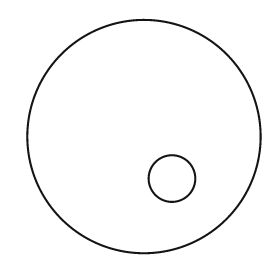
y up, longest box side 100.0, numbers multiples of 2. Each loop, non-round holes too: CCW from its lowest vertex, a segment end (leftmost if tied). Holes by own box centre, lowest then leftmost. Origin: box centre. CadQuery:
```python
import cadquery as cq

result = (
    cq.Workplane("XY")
    .moveTo(0.0, 0.0)
    .circle(50.0)
    .moveTo(12.0, -18.0)
    .circle(10.0)
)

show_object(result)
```